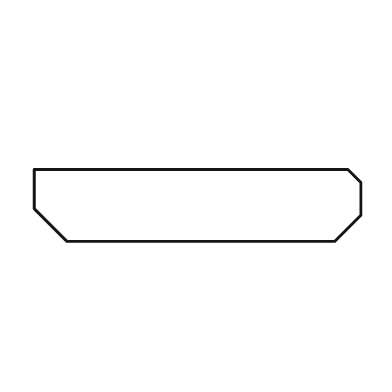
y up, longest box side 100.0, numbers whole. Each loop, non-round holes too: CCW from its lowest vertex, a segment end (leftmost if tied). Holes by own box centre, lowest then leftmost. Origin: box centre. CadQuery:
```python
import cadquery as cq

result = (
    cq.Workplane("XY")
    .moveTo(-40.0, -11.0)
    .lineTo(42.0, -11.0)
    .lineTo(50.0, -3.0)
    .lineTo(50.0, 7.0)
    .lineTo(46.0, 11.0)
    .lineTo(-50.0, 11.0)
    .lineTo(-50.0, -1.0)
    .close()
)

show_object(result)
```